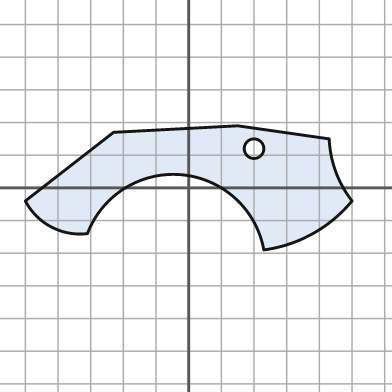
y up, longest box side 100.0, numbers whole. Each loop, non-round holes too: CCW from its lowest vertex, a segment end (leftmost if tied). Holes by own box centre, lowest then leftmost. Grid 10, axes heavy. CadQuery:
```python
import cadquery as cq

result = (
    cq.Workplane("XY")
    .moveTo(23.0, -19.0)
    .threePointArc((38.0, -14.0), (50.0, -4.0))
    .threePointArc((45.0, 5.0), (43.0, 15.0))
    .lineTo(15.0, 19.0)
    .lineTo(-23.0, 17.0)
    .lineTo(-50.0, -4.0)
    .threePointArc((-42.0, -12.0), (-31.0, -14.0))
    .threePointArc((-2.0, 4.0), (23.0, -19.0))
    .close()
    .moveTo(20.0, 12.0)
    .circle(3.0)
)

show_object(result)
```